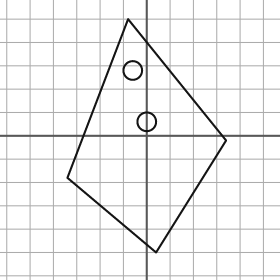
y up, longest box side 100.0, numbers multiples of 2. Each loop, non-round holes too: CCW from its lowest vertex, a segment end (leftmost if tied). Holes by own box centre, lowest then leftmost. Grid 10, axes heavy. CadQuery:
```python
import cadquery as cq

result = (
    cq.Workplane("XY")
    .moveTo(4.0, -50.0)
    .lineTo(34.0, -2.0)
    .lineTo(-8.0, 50.0)
    .lineTo(-34.0, -18.0)
    .close()
    .moveTo(0.0, 6.0)
    .circle(4.0)
    .moveTo(-6.0, 28.0)
    .circle(4.0)
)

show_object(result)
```